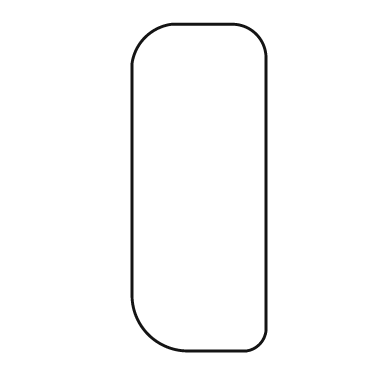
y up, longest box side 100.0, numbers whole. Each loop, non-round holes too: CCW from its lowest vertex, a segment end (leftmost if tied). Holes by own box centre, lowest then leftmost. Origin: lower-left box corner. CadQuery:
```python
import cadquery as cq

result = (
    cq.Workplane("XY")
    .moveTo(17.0, 0.0)
    .lineTo(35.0, 0.0)
    .threePointArc((39.0, 2.0), (41.0, 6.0))
    .lineTo(41.0, 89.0)
    .threePointArc((38.0, 97.0), (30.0, 100.0))
    .lineTo(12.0, 100.0)
    .threePointArc((4.0, 96.0), (0.0, 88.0))
    .lineTo(0.0, 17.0)
    .threePointArc((5.0, 5.0), (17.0, 0.0))
    .close()
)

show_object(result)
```